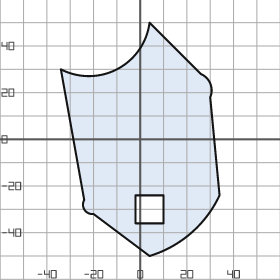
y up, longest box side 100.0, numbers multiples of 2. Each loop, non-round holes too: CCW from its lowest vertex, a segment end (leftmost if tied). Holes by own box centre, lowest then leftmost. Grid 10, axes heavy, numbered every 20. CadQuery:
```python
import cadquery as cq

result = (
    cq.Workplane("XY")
    .moveTo(4.0, -50.0)
    .threePointArc((22.0, -40.0), (34.0, -24.0))
    .lineTo(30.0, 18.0)
    .threePointArc((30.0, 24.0), (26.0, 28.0))
    .lineTo(4.0, 50.0)
    .threePointArc((-10.0, 30.0), (-34.0, 30.0))
    .lineTo(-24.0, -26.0)
    .threePointArc((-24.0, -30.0), (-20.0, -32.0))
    .close()
    .moveTo(-2.0, -36.0)
    .lineTo(10.0, -36.0)
    .lineTo(10.0, -24.0)
    .lineTo(-2.0, -24.0)
    .close()
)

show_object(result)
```